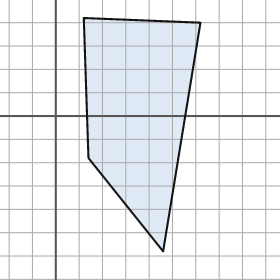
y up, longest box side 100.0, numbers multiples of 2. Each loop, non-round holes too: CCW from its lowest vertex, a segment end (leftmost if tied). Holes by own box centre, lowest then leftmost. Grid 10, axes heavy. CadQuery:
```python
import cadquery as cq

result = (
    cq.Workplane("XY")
    .moveTo(46.0, -58.0)
    .lineTo(62.0, 40.0)
    .lineTo(12.0, 42.0)
    .lineTo(14.0, -18.0)
    .close()
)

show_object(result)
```